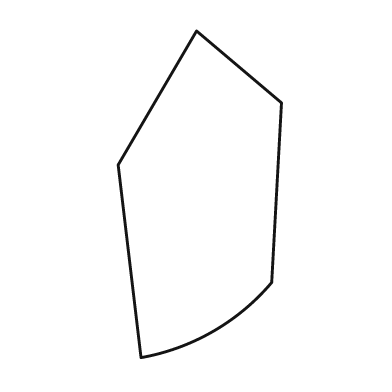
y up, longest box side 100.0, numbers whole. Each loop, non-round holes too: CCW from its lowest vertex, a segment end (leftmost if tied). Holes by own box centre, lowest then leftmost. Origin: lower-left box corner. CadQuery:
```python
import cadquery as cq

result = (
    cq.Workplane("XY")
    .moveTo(7.0, 0.0)
    .threePointArc((29.0, 8.0), (47.0, 23.0))
    .lineTo(50.0, 78.0)
    .lineTo(24.0, 100.0)
    .lineTo(0.0, 59.0)
    .close()
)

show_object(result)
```